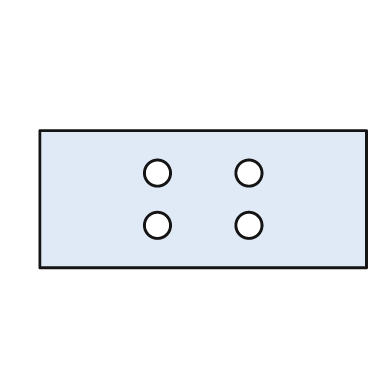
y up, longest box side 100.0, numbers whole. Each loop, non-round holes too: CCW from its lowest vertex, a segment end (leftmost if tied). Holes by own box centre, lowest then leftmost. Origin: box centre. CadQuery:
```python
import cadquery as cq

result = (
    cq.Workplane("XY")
    .moveTo(-50.0, -21.0)
    .lineTo(50.0, -21.0)
    .lineTo(50.0, 21.0)
    .lineTo(-50.0, 21.0)
    .close()
    .moveTo(-14.0, -8.0)
    .circle(4.0)
    .moveTo(14.0, -8.0)
    .circle(4.0)
    .moveTo(-14.0, 8.0)
    .circle(4.0)
    .moveTo(14.0, 8.0)
    .circle(4.0)
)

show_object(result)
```